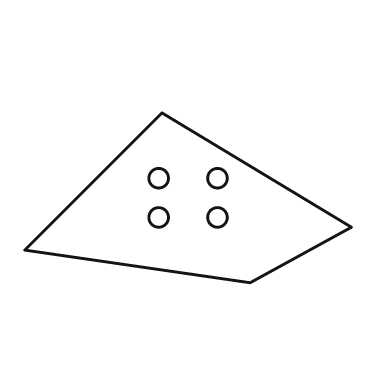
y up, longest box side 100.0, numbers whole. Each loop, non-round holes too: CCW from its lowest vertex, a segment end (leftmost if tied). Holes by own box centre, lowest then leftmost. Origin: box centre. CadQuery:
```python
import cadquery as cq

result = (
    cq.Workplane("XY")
    .moveTo(19.0, -26.0)
    .lineTo(50.0, -9.0)
    .lineTo(-8.0, 26.0)
    .lineTo(-50.0, -16.0)
    .close()
    .moveTo(-9.0, -6.0)
    .circle(3.0)
    .moveTo(9.0, -6.0)
    .circle(3.0)
    .moveTo(-9.0, 6.0)
    .circle(3.0)
    .moveTo(9.0, 6.0)
    .circle(3.0)
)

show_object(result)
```